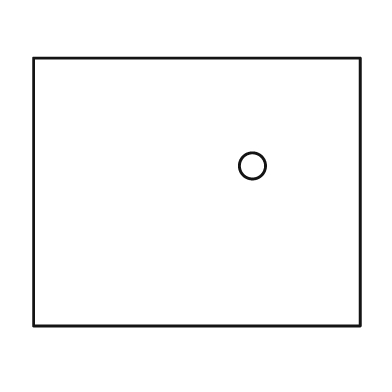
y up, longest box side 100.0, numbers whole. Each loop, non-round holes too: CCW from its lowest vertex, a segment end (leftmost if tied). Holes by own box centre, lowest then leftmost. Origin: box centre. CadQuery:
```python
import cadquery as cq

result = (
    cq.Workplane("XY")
    .moveTo(-50.0, -41.0)
    .lineTo(50.0, -41.0)
    .lineTo(50.0, 41.0)
    .lineTo(-50.0, 41.0)
    .close()
    .moveTo(17.0, 8.0)
    .circle(4.0)
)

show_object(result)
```